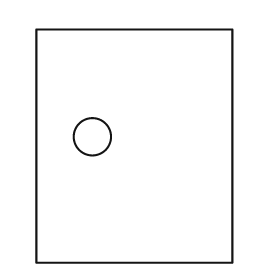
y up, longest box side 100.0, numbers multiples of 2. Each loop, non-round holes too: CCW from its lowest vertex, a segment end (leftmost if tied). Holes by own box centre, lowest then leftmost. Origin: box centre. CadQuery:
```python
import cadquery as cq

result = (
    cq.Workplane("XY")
    .moveTo(-42.0, -50.0)
    .lineTo(42.0, -50.0)
    .lineTo(42.0, 50.0)
    .lineTo(-42.0, 50.0)
    .close()
    .moveTo(-18.0, 4.0)
    .circle(8.0)
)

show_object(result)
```